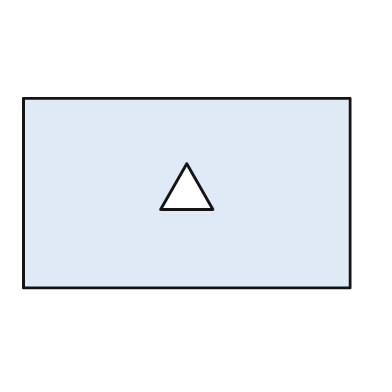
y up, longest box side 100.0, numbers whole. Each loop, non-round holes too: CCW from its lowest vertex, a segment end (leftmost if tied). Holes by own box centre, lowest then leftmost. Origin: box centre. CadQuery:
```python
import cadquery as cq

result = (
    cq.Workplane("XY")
    .moveTo(-50.0, -29.0)
    .lineTo(50.0, -29.0)
    .lineTo(50.0, 29.0)
    .lineTo(-50.0, 29.0)
    .close()
    .moveTo(-8.0, -5.0)
    .lineTo(8.0, -5.0)
    .lineTo(0.0, 9.0)
    .close()
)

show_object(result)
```